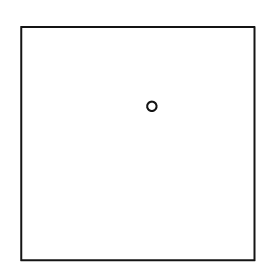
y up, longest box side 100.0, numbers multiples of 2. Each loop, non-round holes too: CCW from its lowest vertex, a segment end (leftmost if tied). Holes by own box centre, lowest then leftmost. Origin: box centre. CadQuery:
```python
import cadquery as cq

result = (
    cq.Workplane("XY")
    .moveTo(-50.0, -50.0)
    .lineTo(50.0, -50.0)
    .lineTo(50.0, 50.0)
    .lineTo(-50.0, 50.0)
    .close()
    .moveTo(6.0, 16.0)
    .circle(2.0)
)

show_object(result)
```